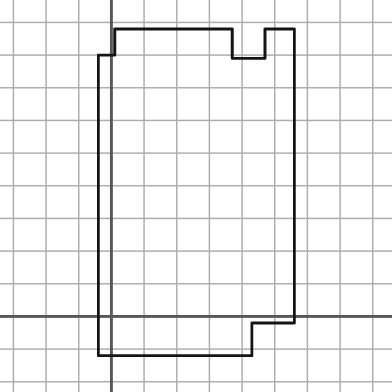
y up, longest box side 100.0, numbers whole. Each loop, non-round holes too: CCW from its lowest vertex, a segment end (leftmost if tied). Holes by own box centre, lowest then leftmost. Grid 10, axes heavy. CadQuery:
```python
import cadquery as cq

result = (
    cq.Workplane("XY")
    .moveTo(-4.0, -12.0)
    .lineTo(43.0, -12.0)
    .lineTo(43.0, -2.0)
    .lineTo(56.0, -2.0)
    .lineTo(56.0, 88.0)
    .lineTo(47.0, 88.0)
    .lineTo(47.0, 79.0)
    .lineTo(37.0, 79.0)
    .lineTo(37.0, 88.0)
    .lineTo(1.0, 88.0)
    .lineTo(1.0, 80.0)
    .lineTo(-4.0, 80.0)
    .close()
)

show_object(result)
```